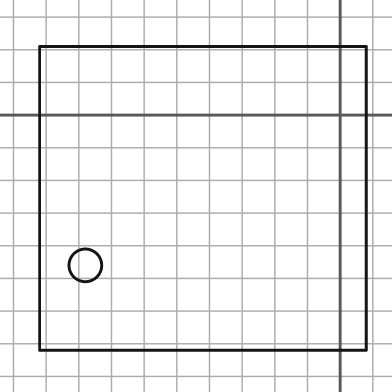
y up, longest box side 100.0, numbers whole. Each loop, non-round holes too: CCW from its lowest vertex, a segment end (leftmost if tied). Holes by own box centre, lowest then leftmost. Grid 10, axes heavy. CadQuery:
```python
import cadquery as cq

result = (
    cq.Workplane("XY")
    .moveTo(-92.0, -72.0)
    .lineTo(8.0, -72.0)
    .lineTo(8.0, 21.0)
    .lineTo(-92.0, 21.0)
    .close()
    .moveTo(-78.0, -46.0)
    .circle(5.0)
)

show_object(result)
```